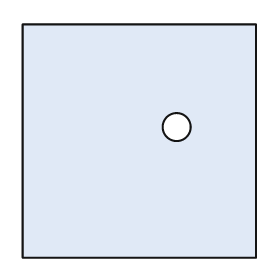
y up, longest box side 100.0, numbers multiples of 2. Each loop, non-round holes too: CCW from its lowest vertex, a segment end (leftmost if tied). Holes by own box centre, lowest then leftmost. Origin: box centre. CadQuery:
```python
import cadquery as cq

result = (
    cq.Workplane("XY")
    .moveTo(-50.0, -50.0)
    .lineTo(50.0, -50.0)
    .lineTo(50.0, 50.0)
    .lineTo(-50.0, 50.0)
    .close()
    .moveTo(16.0, 6.0)
    .circle(6.0)
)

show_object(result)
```